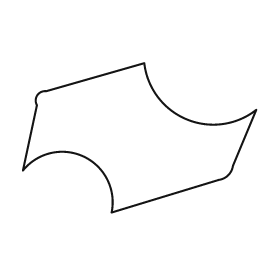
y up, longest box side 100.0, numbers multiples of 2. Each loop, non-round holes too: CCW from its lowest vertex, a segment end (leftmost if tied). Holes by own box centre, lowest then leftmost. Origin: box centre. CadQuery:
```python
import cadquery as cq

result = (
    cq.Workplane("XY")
    .moveTo(-12.0, -32.0)
    .lineTo(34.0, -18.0)
    .threePointArc((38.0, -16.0), (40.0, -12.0))
    .lineTo(50.0, 12.0)
    .threePointArc((20.0, 8.0), (2.0, 32.0))
    .lineTo(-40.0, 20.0)
    .threePointArc((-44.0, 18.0), (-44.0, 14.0))
    .lineTo(-50.0, -14.0)
    .threePointArc((-24.0, -8.0), (-12.0, -32.0))
    .close()
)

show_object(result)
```